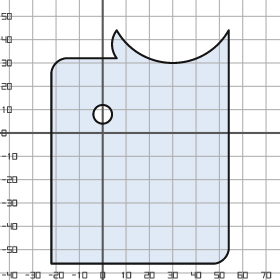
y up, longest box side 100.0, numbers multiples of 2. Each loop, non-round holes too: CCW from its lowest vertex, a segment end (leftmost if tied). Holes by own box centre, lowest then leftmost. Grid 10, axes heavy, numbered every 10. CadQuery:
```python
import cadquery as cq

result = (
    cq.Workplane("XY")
    .moveTo(-22.0, -56.0)
    .lineTo(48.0, -56.0)
    .threePointArc((52.0, -54.0), (54.0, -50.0))
    .lineTo(54.0, 44.0)
    .threePointArc((30.0, 30.0), (6.0, 44.0))
    .threePointArc((4.0, 38.0), (6.0, 32.0))
    .lineTo(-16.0, 32.0)
    .threePointArc((-20.0, 30.0), (-22.0, 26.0))
    .close()
    .moveTo(0.0, 8.0)
    .circle(4.0)
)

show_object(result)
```